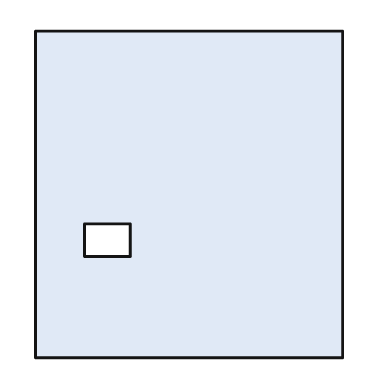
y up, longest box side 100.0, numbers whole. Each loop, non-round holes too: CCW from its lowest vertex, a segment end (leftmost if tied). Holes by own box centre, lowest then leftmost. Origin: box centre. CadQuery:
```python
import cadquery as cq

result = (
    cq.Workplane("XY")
    .moveTo(-47.0, -50.0)
    .lineTo(47.0, -50.0)
    .lineTo(47.0, 50.0)
    .lineTo(-47.0, 50.0)
    .close()
    .moveTo(-32.0, -19.0)
    .lineTo(-18.0, -19.0)
    .lineTo(-18.0, -9.0)
    .lineTo(-32.0, -9.0)
    .close()
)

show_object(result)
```